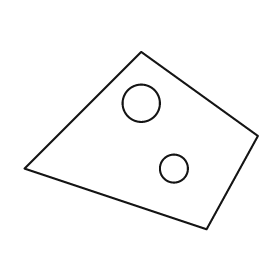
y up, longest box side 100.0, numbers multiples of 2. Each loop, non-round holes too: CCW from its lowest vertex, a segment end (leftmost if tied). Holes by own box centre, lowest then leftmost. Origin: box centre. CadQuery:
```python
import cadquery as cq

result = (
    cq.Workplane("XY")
    .moveTo(28.0, -38.0)
    .lineTo(50.0, 2.0)
    .lineTo(0.0, 38.0)
    .lineTo(-50.0, -12.0)
    .close()
    .moveTo(14.0, -12.0)
    .circle(6.0)
    .moveTo(0.0, 16.0)
    .circle(8.0)
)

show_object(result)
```